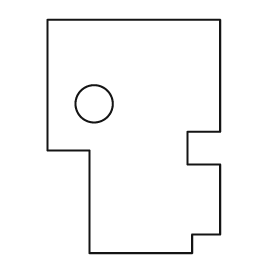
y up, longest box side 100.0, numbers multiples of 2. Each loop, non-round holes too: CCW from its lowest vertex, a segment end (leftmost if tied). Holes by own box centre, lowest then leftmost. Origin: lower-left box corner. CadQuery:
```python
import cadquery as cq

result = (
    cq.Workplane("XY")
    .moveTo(18.0, 0.0)
    .lineTo(62.0, 0.0)
    .lineTo(62.0, 8.0)
    .lineTo(74.0, 8.0)
    .lineTo(74.0, 38.0)
    .lineTo(60.0, 38.0)
    .lineTo(60.0, 52.0)
    .lineTo(74.0, 52.0)
    .lineTo(74.0, 100.0)
    .lineTo(0.0, 100.0)
    .lineTo(0.0, 44.0)
    .lineTo(18.0, 44.0)
    .close()
    .moveTo(20.0, 64.0)
    .circle(8.0)
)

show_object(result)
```